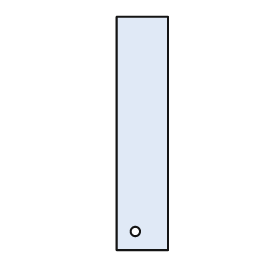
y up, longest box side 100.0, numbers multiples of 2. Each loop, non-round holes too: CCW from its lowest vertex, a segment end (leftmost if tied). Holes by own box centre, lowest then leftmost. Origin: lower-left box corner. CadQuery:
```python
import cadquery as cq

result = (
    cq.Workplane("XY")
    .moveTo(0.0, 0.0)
    .lineTo(22.0, 0.0)
    .lineTo(22.0, 100.0)
    .lineTo(0.0, 100.0)
    .close()
    .moveTo(8.0, 8.0)
    .circle(2.0)
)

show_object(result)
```